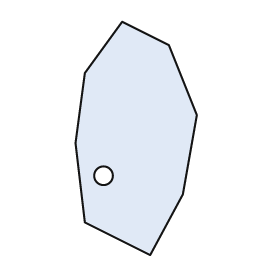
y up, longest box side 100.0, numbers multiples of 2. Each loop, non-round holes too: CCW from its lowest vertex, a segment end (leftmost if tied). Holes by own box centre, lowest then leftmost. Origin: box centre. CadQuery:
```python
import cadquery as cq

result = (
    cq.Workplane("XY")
    .moveTo(6.0, -50.0)
    .lineTo(20.0, -24.0)
    .lineTo(26.0, 10.0)
    .lineTo(14.0, 40.0)
    .lineTo(-6.0, 50.0)
    .lineTo(-22.0, 28.0)
    .lineTo(-26.0, -2.0)
    .lineTo(-22.0, -36.0)
    .close()
    .moveTo(-14.0, -16.0)
    .circle(4.0)
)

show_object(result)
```